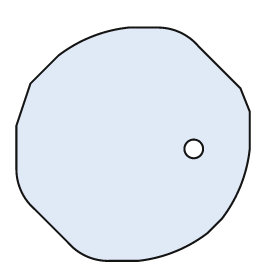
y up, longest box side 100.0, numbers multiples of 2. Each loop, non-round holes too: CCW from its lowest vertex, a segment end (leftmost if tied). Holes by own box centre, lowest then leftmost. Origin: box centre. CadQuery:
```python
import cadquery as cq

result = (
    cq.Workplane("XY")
    .moveTo(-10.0, -50.0)
    .lineTo(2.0, -50.0)
    .threePointArc((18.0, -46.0), (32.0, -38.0))
    .lineTo(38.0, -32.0)
    .threePointArc((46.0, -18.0), (50.0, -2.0))
    .lineTo(50.0, 14.0)
    .lineTo(46.0, 24.0)
    .lineTo(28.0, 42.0)
    .threePointArc((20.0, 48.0), (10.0, 50.0))
    .lineTo(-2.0, 50.0)
    .threePointArc((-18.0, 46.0), (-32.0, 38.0))
    .lineTo(-44.0, 26.0)
    .lineTo(-50.0, 8.0)
    .lineTo(-50.0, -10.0)
    .threePointArc((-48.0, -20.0), (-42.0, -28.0))
    .lineTo(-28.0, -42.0)
    .threePointArc((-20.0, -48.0), (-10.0, -50.0))
    .close()
    .moveTo(26.0, -2.0)
    .circle(4.0)
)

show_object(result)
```